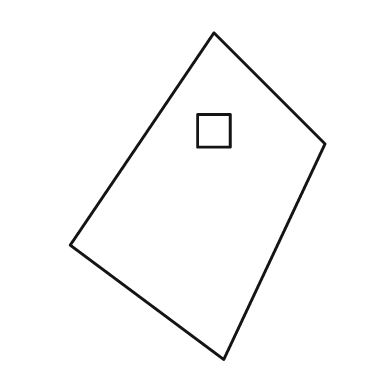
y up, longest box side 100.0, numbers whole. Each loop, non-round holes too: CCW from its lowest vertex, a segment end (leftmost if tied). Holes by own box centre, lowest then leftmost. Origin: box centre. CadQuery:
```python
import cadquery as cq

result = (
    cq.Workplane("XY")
    .moveTo(8.0, -50.0)
    .lineTo(39.0, 16.0)
    .lineTo(5.0, 50.0)
    .lineTo(-39.0, -15.0)
    .close()
    .moveTo(0.0, 15.0)
    .lineTo(10.0, 15.0)
    .lineTo(10.0, 25.0)
    .lineTo(0.0, 25.0)
    .close()
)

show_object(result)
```